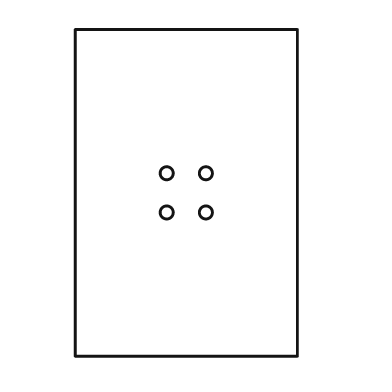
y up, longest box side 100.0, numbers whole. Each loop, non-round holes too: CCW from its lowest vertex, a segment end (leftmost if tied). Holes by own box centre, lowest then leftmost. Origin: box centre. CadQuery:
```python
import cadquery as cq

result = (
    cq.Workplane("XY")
    .moveTo(-34.0, -50.0)
    .lineTo(34.0, -50.0)
    .lineTo(34.0, 50.0)
    .lineTo(-34.0, 50.0)
    .close()
    .moveTo(-6.0, -6.0)
    .circle(2.0)
    .moveTo(6.0, -6.0)
    .circle(2.0)
    .moveTo(-6.0, 6.0)
    .circle(2.0)
    .moveTo(6.0, 6.0)
    .circle(2.0)
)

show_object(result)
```